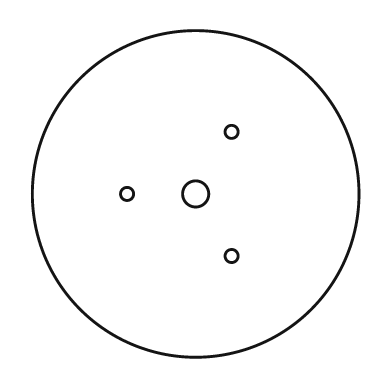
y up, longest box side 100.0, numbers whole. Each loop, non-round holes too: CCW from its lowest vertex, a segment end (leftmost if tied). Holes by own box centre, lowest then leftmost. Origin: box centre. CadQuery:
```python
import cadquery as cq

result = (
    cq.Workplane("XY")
    .moveTo(0.0, 0.0)
    .circle(50.0)
    .moveTo(11.0, -19.0)
    .circle(2.0)
    .moveTo(-21.0, 0.0)
    .circle(2.0)
    .moveTo(0.0, 0.0)
    .circle(4.0)
    .moveTo(11.0, 19.0)
    .circle(2.0)
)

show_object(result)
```